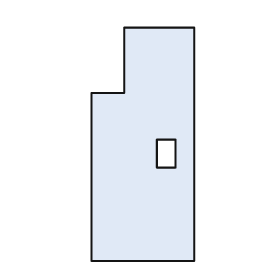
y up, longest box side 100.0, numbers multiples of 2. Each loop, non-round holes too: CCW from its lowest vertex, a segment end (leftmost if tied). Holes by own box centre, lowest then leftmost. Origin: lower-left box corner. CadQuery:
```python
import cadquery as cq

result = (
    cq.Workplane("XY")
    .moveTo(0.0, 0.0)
    .lineTo(44.0, 0.0)
    .lineTo(44.0, 100.0)
    .lineTo(14.0, 100.0)
    .lineTo(14.0, 72.0)
    .lineTo(0.0, 72.0)
    .close()
    .moveTo(28.0, 40.0)
    .lineTo(36.0, 40.0)
    .lineTo(36.0, 52.0)
    .lineTo(28.0, 52.0)
    .close()
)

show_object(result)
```